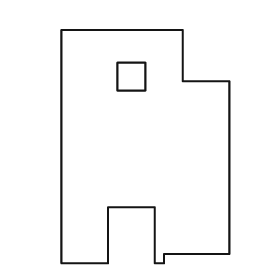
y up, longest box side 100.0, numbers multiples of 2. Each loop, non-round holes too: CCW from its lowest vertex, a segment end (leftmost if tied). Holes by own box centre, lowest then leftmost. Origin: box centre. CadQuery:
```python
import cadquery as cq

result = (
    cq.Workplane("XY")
    .moveTo(-36.0, -50.0)
    .lineTo(-16.0, -50.0)
    .lineTo(-16.0, -26.0)
    .lineTo(4.0, -26.0)
    .lineTo(4.0, -50.0)
    .lineTo(8.0, -50.0)
    .lineTo(8.0, -46.0)
    .lineTo(36.0, -46.0)
    .lineTo(36.0, 28.0)
    .lineTo(16.0, 28.0)
    .lineTo(16.0, 50.0)
    .lineTo(-36.0, 50.0)
    .close()
    .moveTo(-12.0, 24.0)
    .lineTo(0.0, 24.0)
    .lineTo(0.0, 36.0)
    .lineTo(-12.0, 36.0)
    .close()
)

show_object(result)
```